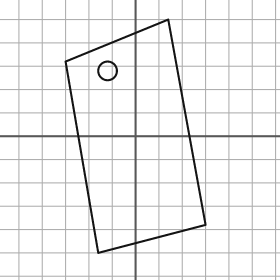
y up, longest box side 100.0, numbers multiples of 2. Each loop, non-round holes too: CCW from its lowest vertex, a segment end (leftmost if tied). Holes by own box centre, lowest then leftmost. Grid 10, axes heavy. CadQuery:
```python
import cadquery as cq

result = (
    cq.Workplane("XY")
    .moveTo(-16.0, -50.0)
    .lineTo(30.0, -38.0)
    .lineTo(14.0, 50.0)
    .lineTo(-30.0, 32.0)
    .close()
    .moveTo(-12.0, 28.0)
    .circle(4.0)
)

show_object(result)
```